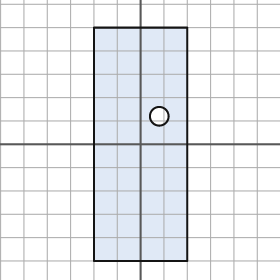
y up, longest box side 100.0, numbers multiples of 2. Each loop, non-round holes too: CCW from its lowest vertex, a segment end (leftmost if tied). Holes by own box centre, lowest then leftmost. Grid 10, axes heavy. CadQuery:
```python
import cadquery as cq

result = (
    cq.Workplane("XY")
    .moveTo(-20.0, -50.0)
    .lineTo(20.0, -50.0)
    .lineTo(20.0, 50.0)
    .lineTo(-20.0, 50.0)
    .close()
    .moveTo(8.0, 12.0)
    .circle(4.0)
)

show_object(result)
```